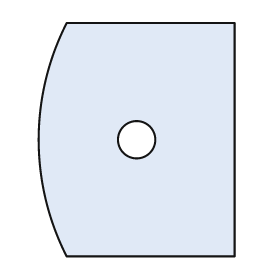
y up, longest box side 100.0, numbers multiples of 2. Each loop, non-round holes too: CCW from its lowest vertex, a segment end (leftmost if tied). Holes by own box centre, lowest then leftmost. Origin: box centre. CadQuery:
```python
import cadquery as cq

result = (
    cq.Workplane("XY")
    .moveTo(-30.0, -50.0)
    .lineTo(42.0, -50.0)
    .lineTo(42.0, 50.0)
    .lineTo(-30.0, 50.0)
    .threePointArc((-42.0, 0.0), (-30.0, -50.0))
    .close()
    .moveTo(0.0, 0.0)
    .circle(8.0)
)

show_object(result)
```